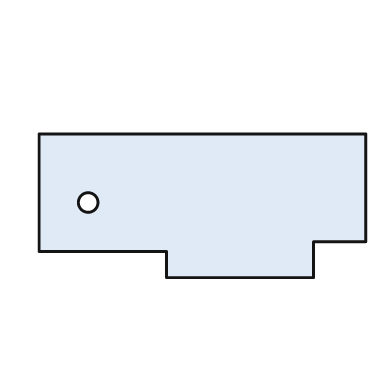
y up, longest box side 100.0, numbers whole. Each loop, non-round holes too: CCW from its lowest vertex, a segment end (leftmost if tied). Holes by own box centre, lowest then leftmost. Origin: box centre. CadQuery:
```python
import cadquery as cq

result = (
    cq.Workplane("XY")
    .moveTo(-11.0, -22.0)
    .lineTo(34.0, -22.0)
    .lineTo(34.0, -11.0)
    .lineTo(50.0, -11.0)
    .lineTo(50.0, 22.0)
    .lineTo(-50.0, 22.0)
    .lineTo(-50.0, -14.0)
    .lineTo(-11.0, -14.0)
    .close()
    .moveTo(-35.0, 1.0)
    .circle(3.0)
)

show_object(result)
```